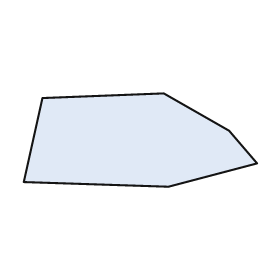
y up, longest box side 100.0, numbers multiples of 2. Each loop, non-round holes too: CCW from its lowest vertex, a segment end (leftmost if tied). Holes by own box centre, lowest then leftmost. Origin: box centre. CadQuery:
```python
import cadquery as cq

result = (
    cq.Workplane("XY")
    .moveTo(12.0, -20.0)
    .lineTo(50.0, -10.0)
    .lineTo(38.0, 4.0)
    .lineTo(10.0, 20.0)
    .lineTo(-42.0, 18.0)
    .lineTo(-50.0, -18.0)
    .close()
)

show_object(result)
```